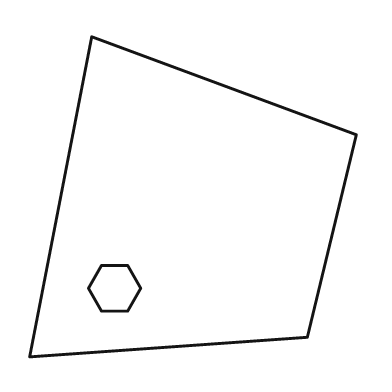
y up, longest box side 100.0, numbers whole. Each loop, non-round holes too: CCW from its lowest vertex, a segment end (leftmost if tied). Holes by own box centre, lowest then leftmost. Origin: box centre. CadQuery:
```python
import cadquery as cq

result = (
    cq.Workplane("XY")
    .moveTo(-50.0, -49.0)
    .lineTo(35.0, -43.0)
    .lineTo(50.0, 19.0)
    .lineTo(-31.0, 49.0)
    .close()
    .moveTo(-28.0, -35.0)
    .lineTo(-20.0, -35.0)
    .lineTo(-16.0, -28.0)
    .lineTo(-20.0, -21.0)
    .lineTo(-28.0, -21.0)
    .lineTo(-32.0, -28.0)
    .close()
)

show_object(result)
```